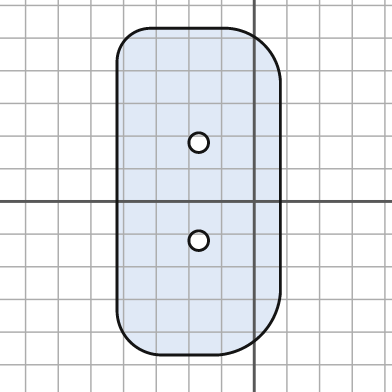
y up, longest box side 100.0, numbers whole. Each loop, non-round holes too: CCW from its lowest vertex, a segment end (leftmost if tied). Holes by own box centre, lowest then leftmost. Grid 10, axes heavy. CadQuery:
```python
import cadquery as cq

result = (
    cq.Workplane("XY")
    .moveTo(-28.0, -47.0)
    .lineTo(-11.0, -47.0)
    .threePointArc((2.0, -41.0), (8.0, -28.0))
    .lineTo(8.0, 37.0)
    .threePointArc((3.0, 48.0), (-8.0, 53.0))
    .lineTo(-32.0, 53.0)
    .threePointArc((-39.0, 50.0), (-42.0, 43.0))
    .lineTo(-42.0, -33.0)
    .threePointArc((-38.0, -43.0), (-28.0, -47.0))
    .close()
    .moveTo(-17.0, -12.0)
    .circle(3.0)
    .moveTo(-17.0, 18.0)
    .circle(3.0)
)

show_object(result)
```